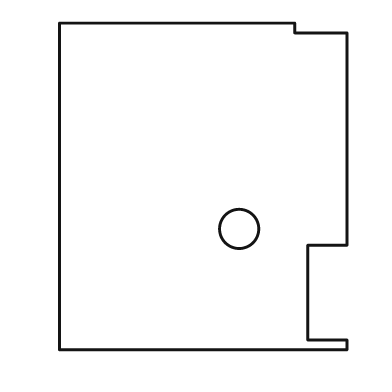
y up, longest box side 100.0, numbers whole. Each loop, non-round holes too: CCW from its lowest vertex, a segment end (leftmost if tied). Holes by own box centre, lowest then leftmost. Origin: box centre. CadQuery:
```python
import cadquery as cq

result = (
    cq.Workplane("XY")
    .moveTo(-44.0, -50.0)
    .lineTo(44.0, -50.0)
    .lineTo(44.0, -47.0)
    .lineTo(32.0, -47.0)
    .lineTo(32.0, -18.0)
    .lineTo(44.0, -18.0)
    .lineTo(44.0, 47.0)
    .lineTo(28.0, 47.0)
    .lineTo(28.0, 50.0)
    .lineTo(-44.0, 50.0)
    .close()
    .moveTo(11.0, -13.0)
    .circle(6.0)
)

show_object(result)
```